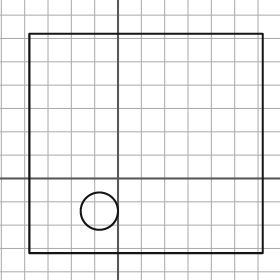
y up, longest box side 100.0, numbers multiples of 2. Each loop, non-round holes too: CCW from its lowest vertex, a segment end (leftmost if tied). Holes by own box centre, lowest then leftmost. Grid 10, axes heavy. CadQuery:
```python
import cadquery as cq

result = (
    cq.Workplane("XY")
    .moveTo(-38.0, -32.0)
    .lineTo(62.0, -32.0)
    .lineTo(62.0, 62.0)
    .lineTo(-38.0, 62.0)
    .close()
    .moveTo(-8.0, -14.0)
    .circle(8.0)
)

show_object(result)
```